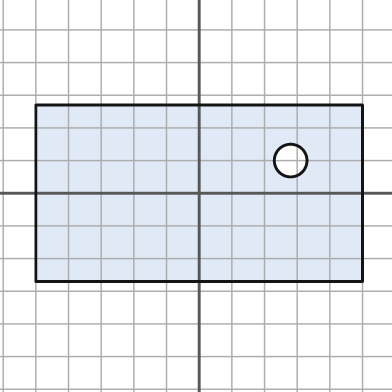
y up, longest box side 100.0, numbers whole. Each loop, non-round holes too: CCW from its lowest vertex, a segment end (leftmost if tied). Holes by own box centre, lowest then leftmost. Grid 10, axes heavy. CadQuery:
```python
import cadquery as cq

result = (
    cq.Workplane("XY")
    .moveTo(-50.0, -27.0)
    .lineTo(50.0, -27.0)
    .lineTo(50.0, 27.0)
    .lineTo(-50.0, 27.0)
    .close()
    .moveTo(28.0, 10.0)
    .circle(5.0)
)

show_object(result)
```